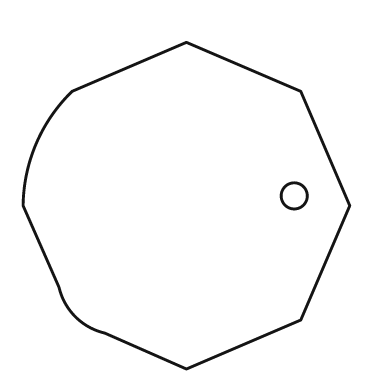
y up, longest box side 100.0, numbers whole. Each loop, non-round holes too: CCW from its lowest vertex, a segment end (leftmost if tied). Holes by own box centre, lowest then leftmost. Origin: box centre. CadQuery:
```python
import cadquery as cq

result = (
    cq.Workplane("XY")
    .moveTo(0.0, -50.0)
    .lineTo(35.0, -35.0)
    .lineTo(50.0, 0.0)
    .lineTo(35.0, 35.0)
    .lineTo(0.0, 50.0)
    .lineTo(-35.0, 35.0)
    .threePointArc((-46.0, 19.0), (-50.0, 0.0))
    .lineTo(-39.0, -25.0)
    .threePointArc((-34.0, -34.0), (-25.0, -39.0))
    .close()
    .moveTo(33.0, 3.0)
    .circle(4.0)
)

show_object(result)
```